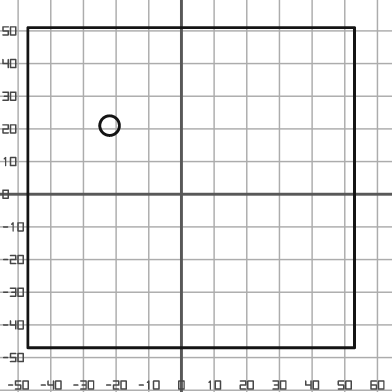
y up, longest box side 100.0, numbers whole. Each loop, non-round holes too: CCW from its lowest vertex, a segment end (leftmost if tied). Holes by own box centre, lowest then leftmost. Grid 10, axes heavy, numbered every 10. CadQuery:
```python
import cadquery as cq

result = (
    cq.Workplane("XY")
    .moveTo(-47.0, -47.0)
    .lineTo(53.0, -47.0)
    .lineTo(53.0, 51.0)
    .lineTo(-47.0, 51.0)
    .close()
    .moveTo(-22.0, 21.0)
    .circle(3.0)
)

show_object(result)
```